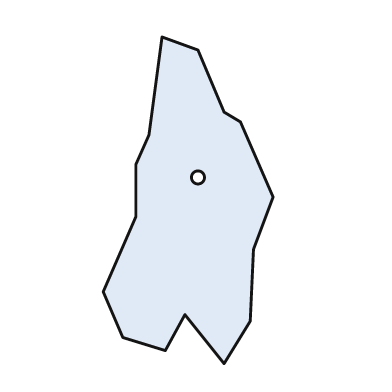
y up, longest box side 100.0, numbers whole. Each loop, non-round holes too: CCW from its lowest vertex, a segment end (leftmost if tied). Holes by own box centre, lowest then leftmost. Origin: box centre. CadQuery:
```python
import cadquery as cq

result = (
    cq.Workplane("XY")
    .moveTo(11.0, -50.0)
    .lineTo(19.0, -37.0)
    .lineTo(20.0, -15.0)
    .lineTo(26.0, 1.0)
    .lineTo(16.0, 24.0)
    .lineTo(11.0, 27.0)
    .lineTo(3.0, 46.0)
    .lineTo(-8.0, 50.0)
    .lineTo(-12.0, 20.0)
    .lineTo(-16.0, 11.0)
    .lineTo(-16.0, -5.0)
    .lineTo(-26.0, -28.0)
    .lineTo(-20.0, -42.0)
    .lineTo(-7.0, -46.0)
    .lineTo(-1.0, -35.0)
    .close()
    .moveTo(3.0, 7.0)
    .circle(2.0)
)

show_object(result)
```